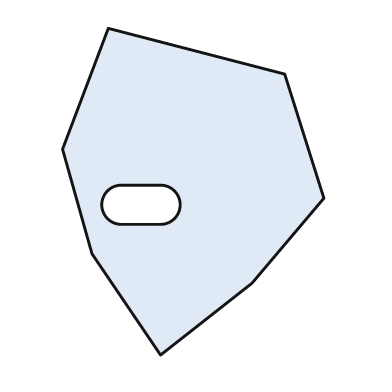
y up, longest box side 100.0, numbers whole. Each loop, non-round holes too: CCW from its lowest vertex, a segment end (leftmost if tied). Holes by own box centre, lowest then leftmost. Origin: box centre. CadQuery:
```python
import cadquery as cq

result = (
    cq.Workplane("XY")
    .moveTo(-10.0, -50.0)
    .lineTo(18.0, -28.0)
    .lineTo(40.0, -2.0)
    .lineTo(28.0, 36.0)
    .lineTo(-26.0, 50.0)
    .lineTo(-40.0, 13.0)
    .lineTo(-31.0, -19.0)
    .close()
    .moveTo(-22.0, -10.0)
    .lineTo(-10.0, -10.0)
    .threePointArc((-4.0, -4.0), (-10.0, 2.0))
    .lineTo(-22.0, 2.0)
    .threePointArc((-28.0, -4.0), (-22.0, -10.0))
    .close()
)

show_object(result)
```